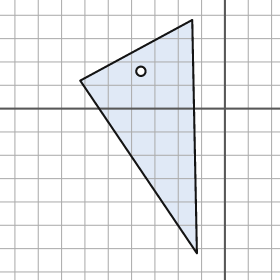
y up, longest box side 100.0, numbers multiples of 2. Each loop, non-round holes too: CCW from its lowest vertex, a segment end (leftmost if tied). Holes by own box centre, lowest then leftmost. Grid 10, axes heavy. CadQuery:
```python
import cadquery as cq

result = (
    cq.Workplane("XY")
    .moveTo(-12.0, -62.0)
    .lineTo(-14.0, 38.0)
    .lineTo(-62.0, 12.0)
    .close()
    .moveTo(-36.0, 16.0)
    .circle(2.0)
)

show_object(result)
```